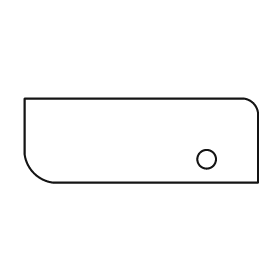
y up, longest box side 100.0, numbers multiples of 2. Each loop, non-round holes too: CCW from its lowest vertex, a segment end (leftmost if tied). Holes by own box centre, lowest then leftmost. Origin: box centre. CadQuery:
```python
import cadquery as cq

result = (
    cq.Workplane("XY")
    .moveTo(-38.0, -18.0)
    .lineTo(50.0, -18.0)
    .lineTo(50.0, 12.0)
    .threePointArc((48.0, 16.0), (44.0, 18.0))
    .lineTo(-50.0, 18.0)
    .lineTo(-50.0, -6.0)
    .threePointArc((-46.0, -14.0), (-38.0, -18.0))
    .close()
    .moveTo(28.0, -8.0)
    .circle(4.0)
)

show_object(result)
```